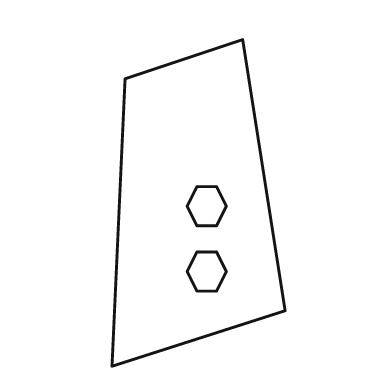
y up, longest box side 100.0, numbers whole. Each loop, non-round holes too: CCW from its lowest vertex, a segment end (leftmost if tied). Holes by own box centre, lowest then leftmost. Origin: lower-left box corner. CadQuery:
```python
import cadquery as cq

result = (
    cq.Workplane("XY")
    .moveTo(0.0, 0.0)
    .lineTo(53.0, 17.0)
    .lineTo(40.0, 100.0)
    .lineTo(4.0, 88.0)
    .close()
    .moveTo(26.0, 23.0)
    .lineTo(32.0, 23.0)
    .lineTo(35.0, 29.0)
    .lineTo(32.0, 35.0)
    .lineTo(26.0, 35.0)
    .lineTo(23.0, 29.0)
    .close()
    .moveTo(26.0, 43.0)
    .lineTo(32.0, 43.0)
    .lineTo(35.0, 49.0)
    .lineTo(32.0, 55.0)
    .lineTo(26.0, 55.0)
    .lineTo(23.0, 49.0)
    .close()
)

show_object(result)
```